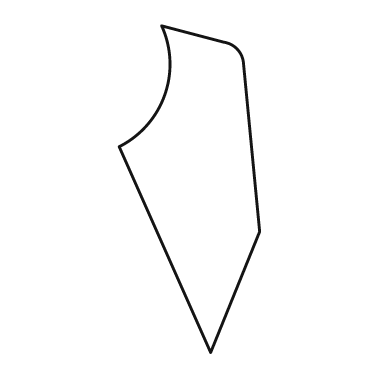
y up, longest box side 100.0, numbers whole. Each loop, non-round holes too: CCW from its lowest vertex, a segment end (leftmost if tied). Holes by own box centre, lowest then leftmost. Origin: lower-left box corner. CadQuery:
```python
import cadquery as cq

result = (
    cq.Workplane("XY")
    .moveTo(28.0, 0.0)
    .lineTo(43.0, 37.0)
    .lineTo(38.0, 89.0)
    .threePointArc((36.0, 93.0), (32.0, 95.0))
    .lineTo(13.0, 100.0)
    .threePointArc((14.0, 79.0), (0.0, 63.0))
    .close()
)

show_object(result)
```